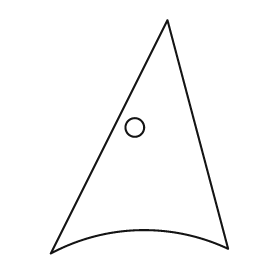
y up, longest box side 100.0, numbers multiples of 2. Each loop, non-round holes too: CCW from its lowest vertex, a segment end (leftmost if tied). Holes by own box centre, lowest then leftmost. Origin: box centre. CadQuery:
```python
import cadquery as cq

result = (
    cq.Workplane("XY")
    .moveTo(-38.0, -50.0)
    .threePointArc((0.0, -40.0), (38.0, -48.0))
    .lineTo(12.0, 50.0)
    .close()
    .moveTo(-2.0, 4.0)
    .circle(4.0)
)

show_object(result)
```